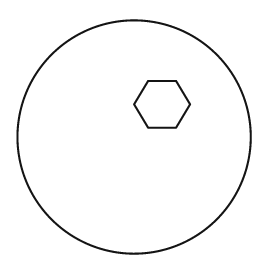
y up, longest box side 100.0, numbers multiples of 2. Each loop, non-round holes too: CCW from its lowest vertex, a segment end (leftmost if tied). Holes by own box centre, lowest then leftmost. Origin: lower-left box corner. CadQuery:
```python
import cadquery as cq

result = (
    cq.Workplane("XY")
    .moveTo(50.0, 50.0)
    .circle(50.0)
    .moveTo(56.0, 54.0)
    .lineTo(68.0, 54.0)
    .lineTo(74.0, 64.0)
    .lineTo(68.0, 74.0)
    .lineTo(56.0, 74.0)
    .lineTo(50.0, 64.0)
    .close()
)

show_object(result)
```